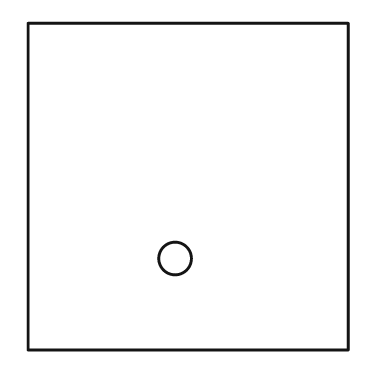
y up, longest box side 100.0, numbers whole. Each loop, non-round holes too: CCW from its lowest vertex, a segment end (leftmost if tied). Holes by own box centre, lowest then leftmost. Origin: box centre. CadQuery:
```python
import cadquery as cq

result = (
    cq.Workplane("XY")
    .moveTo(-49.0, -50.0)
    .lineTo(49.0, -50.0)
    .lineTo(49.0, 50.0)
    .lineTo(-49.0, 50.0)
    .close()
    .moveTo(-4.0, -22.0)
    .circle(5.0)
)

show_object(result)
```